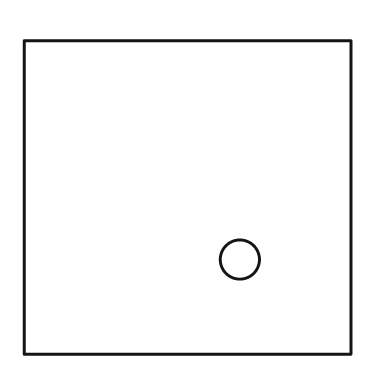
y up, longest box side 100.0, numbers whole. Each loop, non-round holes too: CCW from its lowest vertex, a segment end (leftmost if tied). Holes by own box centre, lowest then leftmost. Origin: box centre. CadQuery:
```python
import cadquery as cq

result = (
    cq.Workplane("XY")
    .moveTo(-50.0, -48.0)
    .lineTo(50.0, -48.0)
    .lineTo(50.0, 48.0)
    .lineTo(-50.0, 48.0)
    .close()
    .moveTo(16.0, -19.0)
    .circle(6.0)
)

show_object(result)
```